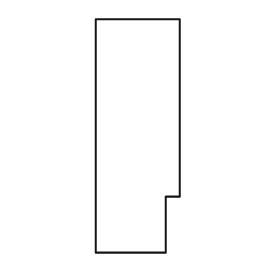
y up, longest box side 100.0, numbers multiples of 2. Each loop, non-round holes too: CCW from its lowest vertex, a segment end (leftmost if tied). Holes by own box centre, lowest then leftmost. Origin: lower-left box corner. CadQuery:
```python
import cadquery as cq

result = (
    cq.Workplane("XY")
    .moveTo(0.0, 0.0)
    .lineTo(30.0, 0.0)
    .lineTo(30.0, 24.0)
    .lineTo(36.0, 24.0)
    .lineTo(36.0, 100.0)
    .lineTo(0.0, 100.0)
    .close()
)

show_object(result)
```